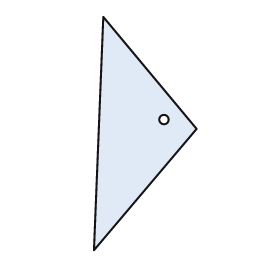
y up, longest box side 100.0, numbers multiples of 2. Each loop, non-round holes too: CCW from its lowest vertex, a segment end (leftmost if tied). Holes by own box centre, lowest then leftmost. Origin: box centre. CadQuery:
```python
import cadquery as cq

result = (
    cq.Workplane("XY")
    .moveTo(-22.0, -50.0)
    .lineTo(22.0, 2.0)
    .lineTo(-18.0, 50.0)
    .close()
    .moveTo(8.0, 6.0)
    .circle(2.0)
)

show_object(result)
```